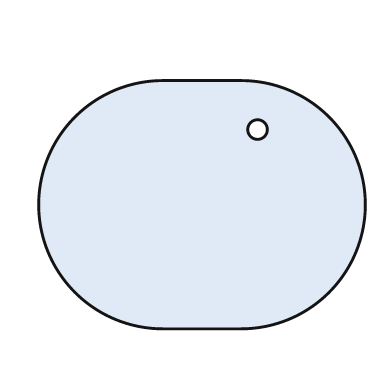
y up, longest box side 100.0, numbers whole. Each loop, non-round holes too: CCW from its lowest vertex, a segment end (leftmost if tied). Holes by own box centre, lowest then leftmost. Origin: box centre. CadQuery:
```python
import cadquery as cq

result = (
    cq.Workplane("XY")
    .moveTo(-12.0, -38.0)
    .lineTo(12.0, -38.0)
    .threePointArc((50.0, 0.0), (12.0, 38.0))
    .lineTo(-12.0, 38.0)
    .threePointArc((-50.0, 0.0), (-12.0, -38.0))
    .close()
    .moveTo(17.0, 23.0)
    .circle(3.0)
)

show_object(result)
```